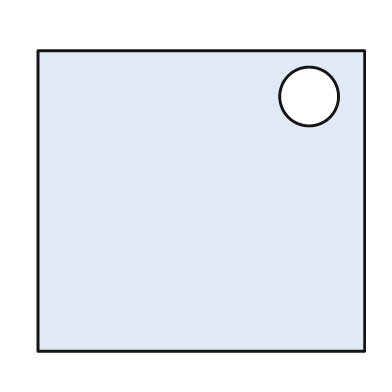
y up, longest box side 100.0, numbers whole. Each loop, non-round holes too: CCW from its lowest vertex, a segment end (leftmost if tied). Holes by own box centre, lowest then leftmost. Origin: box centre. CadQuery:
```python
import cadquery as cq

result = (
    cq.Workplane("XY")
    .moveTo(-50.0, -46.0)
    .lineTo(50.0, -46.0)
    .lineTo(50.0, 46.0)
    .lineTo(-50.0, 46.0)
    .close()
    .moveTo(33.0, 32.0)
    .circle(9.0)
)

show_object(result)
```